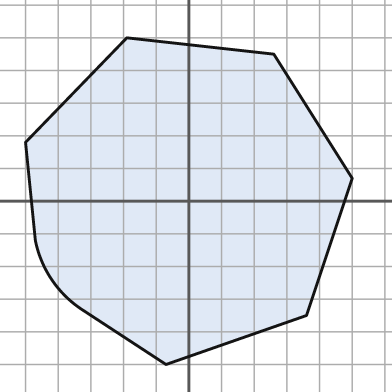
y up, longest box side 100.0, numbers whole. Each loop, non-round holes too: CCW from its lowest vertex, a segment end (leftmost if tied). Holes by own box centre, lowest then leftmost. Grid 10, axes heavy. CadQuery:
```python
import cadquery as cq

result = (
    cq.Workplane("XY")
    .moveTo(-7.0, -50.0)
    .lineTo(36.0, -35.0)
    .lineTo(50.0, 7.0)
    .lineTo(26.0, 45.0)
    .lineTo(-19.0, 50.0)
    .lineTo(-50.0, 18.0)
    .lineTo(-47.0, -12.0)
    .threePointArc((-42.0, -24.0), (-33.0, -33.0))
    .close()
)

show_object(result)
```